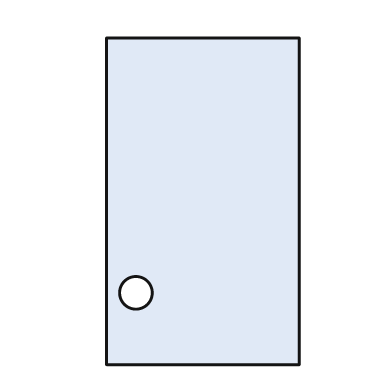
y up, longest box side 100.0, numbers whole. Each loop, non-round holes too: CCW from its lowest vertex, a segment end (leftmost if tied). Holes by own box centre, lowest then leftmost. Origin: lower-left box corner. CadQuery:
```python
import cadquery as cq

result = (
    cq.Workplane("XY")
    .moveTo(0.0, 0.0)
    .lineTo(59.0, 0.0)
    .lineTo(59.0, 100.0)
    .lineTo(0.0, 100.0)
    .close()
    .moveTo(9.0, 22.0)
    .circle(5.0)
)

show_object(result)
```